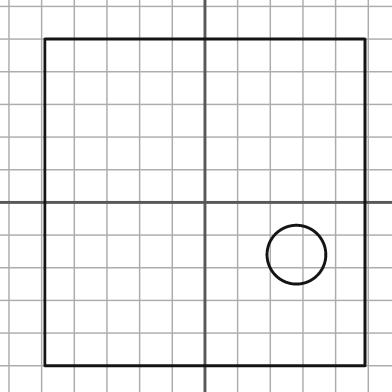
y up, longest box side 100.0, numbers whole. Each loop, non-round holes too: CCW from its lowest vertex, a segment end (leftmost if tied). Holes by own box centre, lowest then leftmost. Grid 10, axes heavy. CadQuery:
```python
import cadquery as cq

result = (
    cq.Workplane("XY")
    .moveTo(-49.0, -50.0)
    .lineTo(49.0, -50.0)
    .lineTo(49.0, 50.0)
    .lineTo(-49.0, 50.0)
    .close()
    .moveTo(28.0, -16.0)
    .circle(9.0)
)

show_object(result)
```